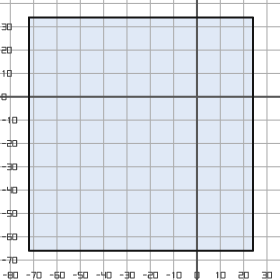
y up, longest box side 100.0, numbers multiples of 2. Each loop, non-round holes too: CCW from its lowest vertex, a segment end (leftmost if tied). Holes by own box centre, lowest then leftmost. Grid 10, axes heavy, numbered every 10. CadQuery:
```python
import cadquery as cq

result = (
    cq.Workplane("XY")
    .moveTo(-72.0, -66.0)
    .lineTo(24.0, -66.0)
    .lineTo(24.0, 34.0)
    .lineTo(-72.0, 34.0)
    .close()
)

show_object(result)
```